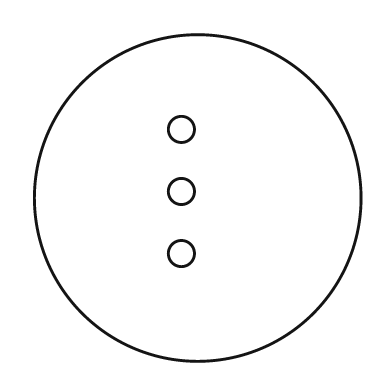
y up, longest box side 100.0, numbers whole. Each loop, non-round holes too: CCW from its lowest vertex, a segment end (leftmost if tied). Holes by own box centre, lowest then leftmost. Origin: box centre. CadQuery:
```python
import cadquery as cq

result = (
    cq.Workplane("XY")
    .moveTo(0.0, 0.0)
    .circle(50.0)
    .moveTo(-5.0, -17.0)
    .circle(4.0)
    .moveTo(-5.0, 2.0)
    .circle(4.0)
    .moveTo(-5.0, 21.0)
    .circle(4.0)
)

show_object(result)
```